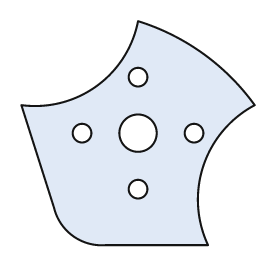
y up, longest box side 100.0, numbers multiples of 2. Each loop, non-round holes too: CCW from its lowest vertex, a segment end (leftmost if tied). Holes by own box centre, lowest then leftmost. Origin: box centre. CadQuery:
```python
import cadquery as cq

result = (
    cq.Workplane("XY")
    .moveTo(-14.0, -48.0)
    .lineTo(30.0, -48.0)
    .threePointArc((28.0, -14.0), (50.0, 12.0))
    .threePointArc((28.0, 34.0), (0.0, 48.0))
    .threePointArc((-18.0, 20.0), (-50.0, 12.0))
    .lineTo(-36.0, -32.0)
    .threePointArc((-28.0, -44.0), (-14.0, -48.0))
    .close()
    .moveTo(0.0, -24.0)
    .circle(4.0)
    .moveTo(-24.0, 0.0)
    .circle(4.0)
    .moveTo(0.0, 0.0)
    .circle(8.0)
    .moveTo(24.0, 0.0)
    .circle(4.0)
    .moveTo(0.0, 24.0)
    .circle(4.0)
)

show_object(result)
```